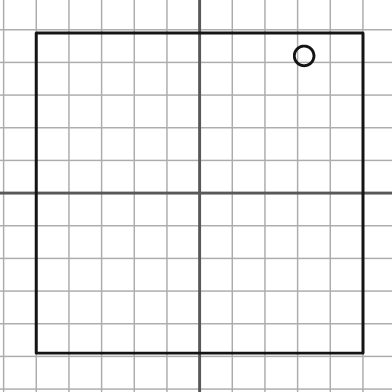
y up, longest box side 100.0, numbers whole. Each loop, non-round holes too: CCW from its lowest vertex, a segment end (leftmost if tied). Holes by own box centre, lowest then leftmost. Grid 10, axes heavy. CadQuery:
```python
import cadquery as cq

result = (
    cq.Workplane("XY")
    .moveTo(-50.0, -49.0)
    .lineTo(50.0, -49.0)
    .lineTo(50.0, 49.0)
    .lineTo(-50.0, 49.0)
    .close()
    .moveTo(32.0, 42.0)
    .circle(3.0)
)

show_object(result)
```